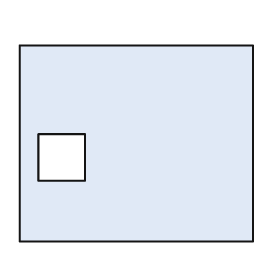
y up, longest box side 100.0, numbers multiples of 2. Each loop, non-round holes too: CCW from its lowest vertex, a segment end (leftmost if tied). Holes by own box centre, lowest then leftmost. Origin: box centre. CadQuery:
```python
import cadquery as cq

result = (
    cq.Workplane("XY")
    .moveTo(-50.0, -42.0)
    .lineTo(50.0, -42.0)
    .lineTo(50.0, 42.0)
    .lineTo(-50.0, 42.0)
    .close()
    .moveTo(-42.0, -16.0)
    .lineTo(-22.0, -16.0)
    .lineTo(-22.0, 4.0)
    .lineTo(-42.0, 4.0)
    .close()
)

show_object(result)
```